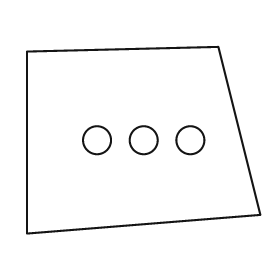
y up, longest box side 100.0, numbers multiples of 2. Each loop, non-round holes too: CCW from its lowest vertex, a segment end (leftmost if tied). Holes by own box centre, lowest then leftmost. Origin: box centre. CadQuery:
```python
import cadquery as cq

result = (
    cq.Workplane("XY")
    .moveTo(-50.0, -40.0)
    .lineTo(50.0, -32.0)
    .lineTo(32.0, 40.0)
    .lineTo(-50.0, 38.0)
    .close()
    .moveTo(-20.0, 0.0)
    .circle(6.0)
    .moveTo(0.0, 0.0)
    .circle(6.0)
    .moveTo(20.0, 0.0)
    .circle(6.0)
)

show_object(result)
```